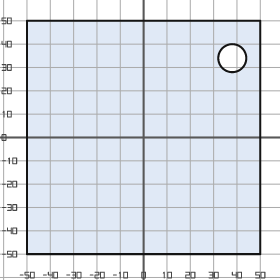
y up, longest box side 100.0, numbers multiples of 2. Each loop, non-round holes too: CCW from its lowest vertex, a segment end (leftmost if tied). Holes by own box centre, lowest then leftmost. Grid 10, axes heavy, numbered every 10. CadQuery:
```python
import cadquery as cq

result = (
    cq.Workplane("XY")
    .moveTo(-50.0, -50.0)
    .lineTo(50.0, -50.0)
    .lineTo(50.0, 50.0)
    .lineTo(-50.0, 50.0)
    .close()
    .moveTo(38.0, 34.0)
    .circle(6.0)
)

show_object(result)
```